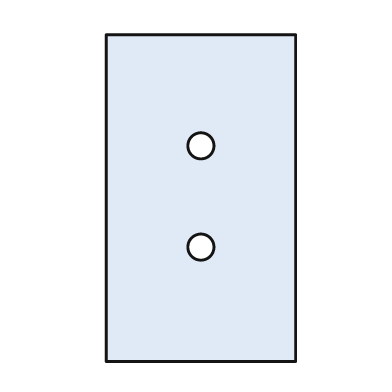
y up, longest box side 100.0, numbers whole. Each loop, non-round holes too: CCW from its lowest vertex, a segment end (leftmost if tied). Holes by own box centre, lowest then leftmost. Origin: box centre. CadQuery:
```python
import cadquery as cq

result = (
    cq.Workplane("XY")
    .moveTo(-29.0, -50.0)
    .lineTo(29.0, -50.0)
    .lineTo(29.0, 50.0)
    .lineTo(-29.0, 50.0)
    .close()
    .moveTo(0.0, -15.0)
    .circle(4.0)
    .moveTo(0.0, 16.0)
    .circle(4.0)
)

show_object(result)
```